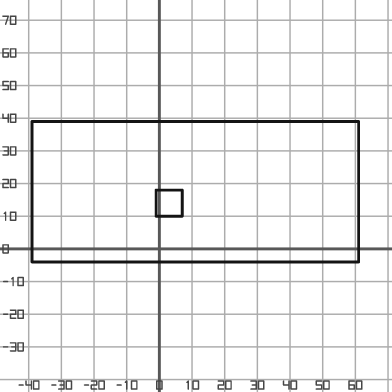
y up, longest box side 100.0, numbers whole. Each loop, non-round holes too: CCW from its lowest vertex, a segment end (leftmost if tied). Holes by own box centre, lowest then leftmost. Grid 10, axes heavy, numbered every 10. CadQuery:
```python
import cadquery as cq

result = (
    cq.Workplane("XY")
    .moveTo(-39.0, -4.0)
    .lineTo(61.0, -4.0)
    .lineTo(61.0, 39.0)
    .lineTo(-39.0, 39.0)
    .close()
    .moveTo(-1.0, 10.0)
    .lineTo(7.0, 10.0)
    .lineTo(7.0, 18.0)
    .lineTo(-1.0, 18.0)
    .close()
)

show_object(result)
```